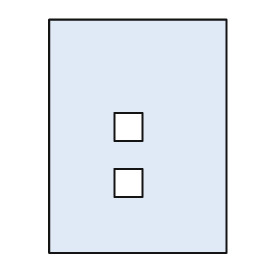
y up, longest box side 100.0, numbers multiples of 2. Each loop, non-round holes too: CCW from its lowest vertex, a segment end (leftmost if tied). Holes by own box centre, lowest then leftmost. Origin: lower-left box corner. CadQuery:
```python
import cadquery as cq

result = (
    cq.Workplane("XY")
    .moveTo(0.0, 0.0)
    .lineTo(76.0, 0.0)
    .lineTo(76.0, 100.0)
    .lineTo(0.0, 100.0)
    .close()
    .moveTo(28.0, 24.0)
    .lineTo(40.0, 24.0)
    .lineTo(40.0, 36.0)
    .lineTo(28.0, 36.0)
    .close()
    .moveTo(28.0, 48.0)
    .lineTo(40.0, 48.0)
    .lineTo(40.0, 60.0)
    .lineTo(28.0, 60.0)
    .close()
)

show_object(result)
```